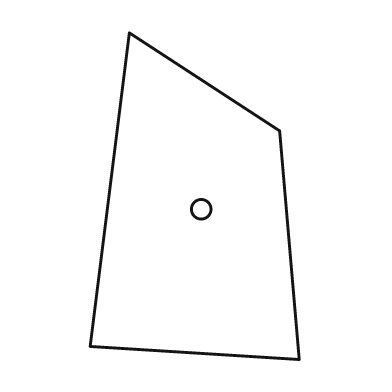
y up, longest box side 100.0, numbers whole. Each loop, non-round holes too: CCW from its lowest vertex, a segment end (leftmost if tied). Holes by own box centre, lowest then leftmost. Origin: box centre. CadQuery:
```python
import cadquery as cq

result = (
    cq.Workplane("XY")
    .moveTo(32.0, -50.0)
    .lineTo(26.0, 20.0)
    .lineTo(-20.0, 50.0)
    .lineTo(-32.0, -46.0)
    .close()
    .moveTo(2.0, -4.0)
    .circle(3.0)
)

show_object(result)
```